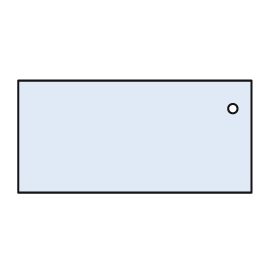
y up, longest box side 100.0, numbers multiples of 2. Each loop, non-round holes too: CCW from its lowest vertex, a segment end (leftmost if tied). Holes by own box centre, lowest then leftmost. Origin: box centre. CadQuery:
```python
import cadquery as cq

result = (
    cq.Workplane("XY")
    .moveTo(-50.0, -24.0)
    .lineTo(50.0, -24.0)
    .lineTo(50.0, 24.0)
    .lineTo(-50.0, 24.0)
    .close()
    .moveTo(42.0, 12.0)
    .circle(2.0)
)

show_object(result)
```